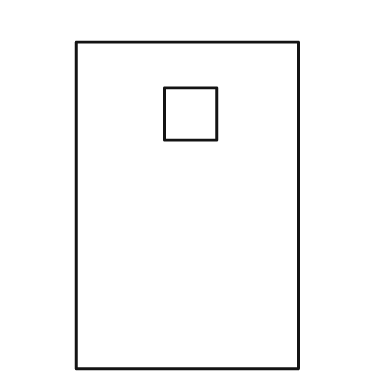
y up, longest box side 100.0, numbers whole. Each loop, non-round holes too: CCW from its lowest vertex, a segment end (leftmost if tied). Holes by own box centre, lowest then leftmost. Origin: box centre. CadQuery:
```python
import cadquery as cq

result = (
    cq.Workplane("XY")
    .moveTo(-34.0, -50.0)
    .lineTo(34.0, -50.0)
    .lineTo(34.0, 50.0)
    .lineTo(-34.0, 50.0)
    .close()
    .moveTo(-7.0, 20.0)
    .lineTo(9.0, 20.0)
    .lineTo(9.0, 36.0)
    .lineTo(-7.0, 36.0)
    .close()
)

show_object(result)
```